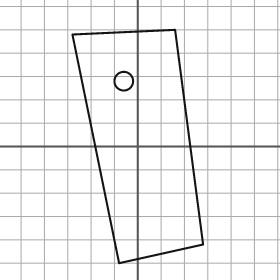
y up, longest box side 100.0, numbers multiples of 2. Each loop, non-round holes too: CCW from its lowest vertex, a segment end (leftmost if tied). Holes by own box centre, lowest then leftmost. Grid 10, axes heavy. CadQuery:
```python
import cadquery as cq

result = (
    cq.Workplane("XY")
    .moveTo(-8.0, -50.0)
    .lineTo(28.0, -42.0)
    .lineTo(16.0, 50.0)
    .lineTo(-28.0, 48.0)
    .close()
    .moveTo(-6.0, 28.0)
    .circle(4.0)
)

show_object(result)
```